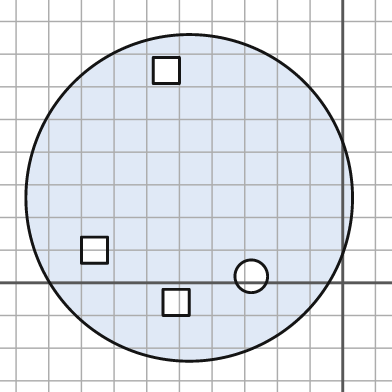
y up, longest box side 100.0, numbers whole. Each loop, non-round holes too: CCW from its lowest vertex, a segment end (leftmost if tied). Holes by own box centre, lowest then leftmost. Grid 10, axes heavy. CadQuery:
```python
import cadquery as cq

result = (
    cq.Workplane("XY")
    .moveTo(-47.0, 26.0)
    .circle(50.0)
    .moveTo(-55.0, -10.0)
    .lineTo(-47.0, -10.0)
    .lineTo(-47.0, -2.0)
    .lineTo(-55.0, -2.0)
    .close()
    .moveTo(-28.0, 2.0)
    .circle(5.0)
    .moveTo(-80.0, 6.0)
    .lineTo(-72.0, 6.0)
    .lineTo(-72.0, 14.0)
    .lineTo(-80.0, 14.0)
    .close()
    .moveTo(-58.0, 61.0)
    .lineTo(-50.0, 61.0)
    .lineTo(-50.0, 69.0)
    .lineTo(-58.0, 69.0)
    .close()
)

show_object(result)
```